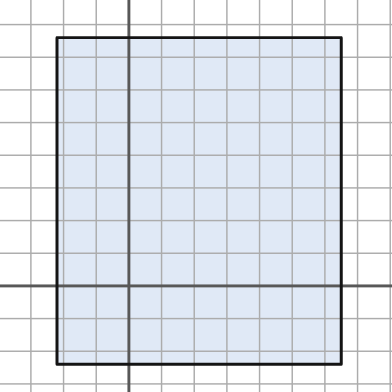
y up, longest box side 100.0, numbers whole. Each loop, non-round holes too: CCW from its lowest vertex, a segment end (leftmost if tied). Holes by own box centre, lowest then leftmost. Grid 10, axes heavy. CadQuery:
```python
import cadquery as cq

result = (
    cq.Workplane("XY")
    .moveTo(-22.0, -24.0)
    .lineTo(65.0, -24.0)
    .lineTo(65.0, 76.0)
    .lineTo(-22.0, 76.0)
    .close()
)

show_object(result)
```